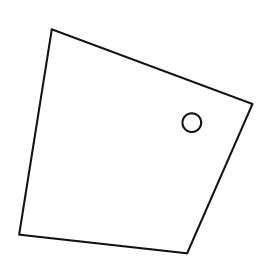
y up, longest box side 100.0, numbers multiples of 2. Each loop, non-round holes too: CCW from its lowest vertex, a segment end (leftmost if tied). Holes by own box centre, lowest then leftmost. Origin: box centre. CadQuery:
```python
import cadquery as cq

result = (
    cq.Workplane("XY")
    .moveTo(22.0, -48.0)
    .lineTo(50.0, 16.0)
    .lineTo(-36.0, 48.0)
    .lineTo(-50.0, -40.0)
    .close()
    .moveTo(24.0, 8.0)
    .circle(4.0)
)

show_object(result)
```